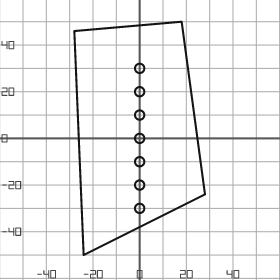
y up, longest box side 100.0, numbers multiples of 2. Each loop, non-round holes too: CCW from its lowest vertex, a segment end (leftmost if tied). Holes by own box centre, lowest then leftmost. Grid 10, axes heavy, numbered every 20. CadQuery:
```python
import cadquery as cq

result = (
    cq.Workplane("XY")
    .moveTo(-24.0, -50.0)
    .lineTo(28.0, -24.0)
    .lineTo(18.0, 50.0)
    .lineTo(-28.0, 46.0)
    .close()
    .moveTo(0.0, -30.0)
    .circle(2.0)
    .moveTo(0.0, -20.0)
    .circle(2.0)
    .moveTo(0.0, -10.0)
    .circle(2.0)
    .moveTo(0.0, 0.0)
    .circle(2.0)
    .moveTo(0.0, 10.0)
    .circle(2.0)
    .moveTo(0.0, 20.0)
    .circle(2.0)
    .moveTo(0.0, 30.0)
    .circle(2.0)
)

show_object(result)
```